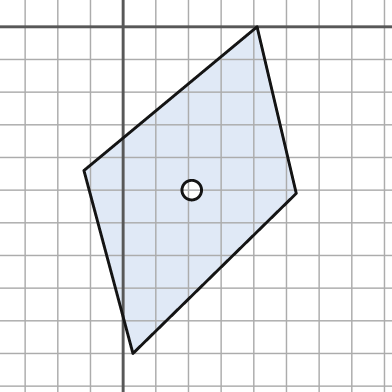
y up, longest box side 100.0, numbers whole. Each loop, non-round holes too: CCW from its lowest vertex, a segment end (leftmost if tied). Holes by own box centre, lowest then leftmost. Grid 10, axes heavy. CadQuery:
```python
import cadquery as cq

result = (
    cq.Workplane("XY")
    .moveTo(3.0, -100.0)
    .lineTo(53.0, -51.0)
    .lineTo(41.0, 0.0)
    .lineTo(-12.0, -44.0)
    .close()
    .moveTo(21.0, -50.0)
    .circle(3.0)
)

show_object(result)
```